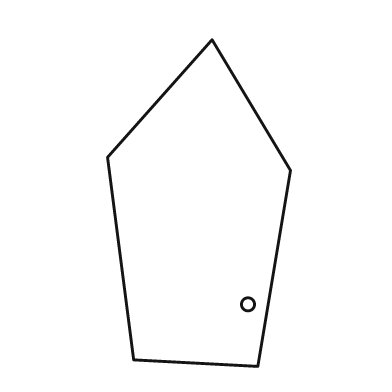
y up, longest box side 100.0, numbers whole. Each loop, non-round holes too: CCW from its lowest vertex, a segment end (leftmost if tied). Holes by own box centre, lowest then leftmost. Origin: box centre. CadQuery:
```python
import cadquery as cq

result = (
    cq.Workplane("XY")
    .moveTo(18.0, -50.0)
    .lineTo(28.0, 10.0)
    .lineTo(4.0, 50.0)
    .lineTo(-28.0, 14.0)
    .lineTo(-20.0, -48.0)
    .close()
    .moveTo(15.0, -31.0)
    .circle(2.0)
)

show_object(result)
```